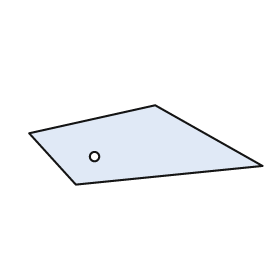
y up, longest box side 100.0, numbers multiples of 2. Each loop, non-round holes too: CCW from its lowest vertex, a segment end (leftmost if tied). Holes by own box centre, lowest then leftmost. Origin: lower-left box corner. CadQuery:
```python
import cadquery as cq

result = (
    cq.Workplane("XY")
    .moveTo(20.0, 0.0)
    .lineTo(100.0, 8.0)
    .lineTo(54.0, 34.0)
    .lineTo(0.0, 22.0)
    .close()
    .moveTo(28.0, 12.0)
    .circle(2.0)
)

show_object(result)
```